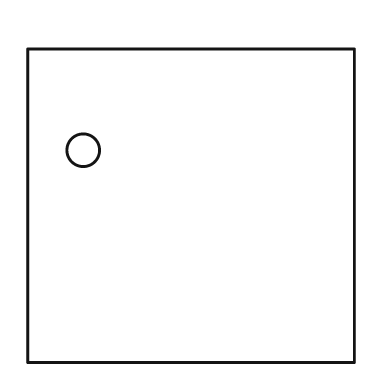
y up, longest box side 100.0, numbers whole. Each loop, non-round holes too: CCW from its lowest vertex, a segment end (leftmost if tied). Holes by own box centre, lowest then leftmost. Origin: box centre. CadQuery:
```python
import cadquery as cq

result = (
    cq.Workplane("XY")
    .moveTo(-50.0, -48.0)
    .lineTo(50.0, -48.0)
    .lineTo(50.0, 48.0)
    .lineTo(-50.0, 48.0)
    .close()
    .moveTo(-33.0, 17.0)
    .circle(5.0)
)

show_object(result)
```